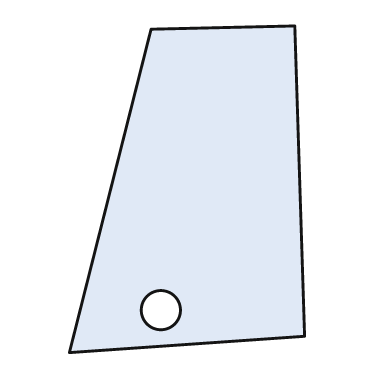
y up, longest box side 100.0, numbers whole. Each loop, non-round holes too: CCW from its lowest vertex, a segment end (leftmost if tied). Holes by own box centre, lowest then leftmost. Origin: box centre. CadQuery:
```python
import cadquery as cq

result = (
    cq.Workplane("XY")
    .moveTo(-36.0, -50.0)
    .lineTo(36.0, -45.0)
    .lineTo(33.0, 50.0)
    .lineTo(-11.0, 49.0)
    .close()
    .moveTo(-8.0, -37.0)
    .circle(6.0)
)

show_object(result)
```